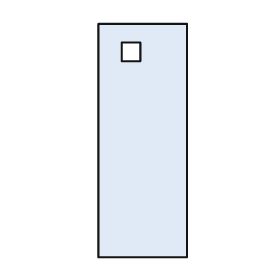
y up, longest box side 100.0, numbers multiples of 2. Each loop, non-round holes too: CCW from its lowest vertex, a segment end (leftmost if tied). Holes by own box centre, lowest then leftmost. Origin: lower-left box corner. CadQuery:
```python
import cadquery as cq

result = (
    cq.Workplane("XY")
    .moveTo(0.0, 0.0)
    .lineTo(38.0, 0.0)
    .lineTo(38.0, 100.0)
    .lineTo(0.0, 100.0)
    .close()
    .moveTo(10.0, 84.0)
    .lineTo(18.0, 84.0)
    .lineTo(18.0, 92.0)
    .lineTo(10.0, 92.0)
    .close()
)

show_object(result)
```